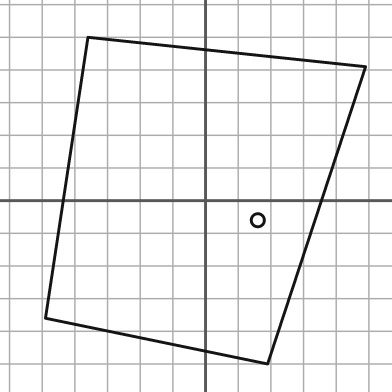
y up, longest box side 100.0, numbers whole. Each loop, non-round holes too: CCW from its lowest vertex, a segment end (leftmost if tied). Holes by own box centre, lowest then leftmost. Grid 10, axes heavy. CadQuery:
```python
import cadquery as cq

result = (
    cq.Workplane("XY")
    .moveTo(19.0, -50.0)
    .lineTo(49.0, 41.0)
    .lineTo(-36.0, 50.0)
    .lineTo(-49.0, -36.0)
    .close()
    .moveTo(16.0, -6.0)
    .circle(2.0)
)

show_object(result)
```